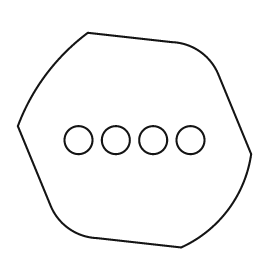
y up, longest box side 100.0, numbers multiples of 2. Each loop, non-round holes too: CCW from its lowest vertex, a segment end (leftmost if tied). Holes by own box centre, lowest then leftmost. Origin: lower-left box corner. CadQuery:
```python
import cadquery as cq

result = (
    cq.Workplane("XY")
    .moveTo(70.0, 0.0)
    .threePointArc((90.0, 16.0), (100.0, 40.0))
    .lineTo(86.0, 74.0)
    .threePointArc((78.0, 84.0), (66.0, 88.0))
    .lineTo(30.0, 92.0)
    .threePointArc((12.0, 74.0), (0.0, 52.0))
    .lineTo(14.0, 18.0)
    .threePointArc((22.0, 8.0), (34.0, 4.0))
    .close()
    .moveTo(26.0, 46.0)
    .circle(6.0)
    .moveTo(42.0, 46.0)
    .circle(6.0)
    .moveTo(58.0, 46.0)
    .circle(6.0)
    .moveTo(74.0, 46.0)
    .circle(6.0)
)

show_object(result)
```